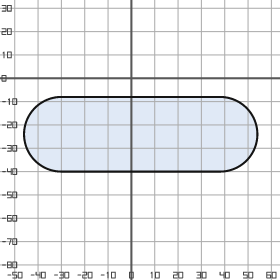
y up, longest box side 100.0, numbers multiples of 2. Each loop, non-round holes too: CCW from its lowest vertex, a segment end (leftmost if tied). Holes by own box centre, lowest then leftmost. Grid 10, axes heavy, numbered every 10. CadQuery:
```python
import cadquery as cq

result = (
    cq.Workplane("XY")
    .moveTo(-30.0, -40.0)
    .lineTo(38.0, -40.0)
    .threePointArc((54.0, -24.0), (38.0, -8.0))
    .lineTo(-30.0, -8.0)
    .threePointArc((-46.0, -24.0), (-30.0, -40.0))
    .close()
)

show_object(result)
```